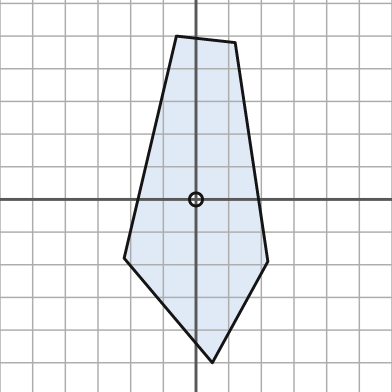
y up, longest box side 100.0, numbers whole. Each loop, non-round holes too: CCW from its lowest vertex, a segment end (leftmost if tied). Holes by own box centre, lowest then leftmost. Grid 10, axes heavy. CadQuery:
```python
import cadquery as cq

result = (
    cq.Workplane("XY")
    .moveTo(5.0, -50.0)
    .lineTo(22.0, -19.0)
    .lineTo(12.0, 48.0)
    .lineTo(-6.0, 50.0)
    .lineTo(-22.0, -18.0)
    .close()
    .moveTo(0.0, 0.0)
    .circle(2.0)
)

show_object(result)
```